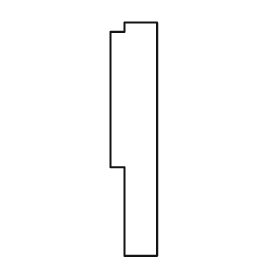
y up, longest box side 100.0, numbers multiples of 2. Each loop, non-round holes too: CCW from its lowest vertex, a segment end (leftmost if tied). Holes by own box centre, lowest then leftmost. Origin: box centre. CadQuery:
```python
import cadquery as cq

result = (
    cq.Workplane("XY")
    .moveTo(-4.0, -50.0)
    .lineTo(10.0, -50.0)
    .lineTo(10.0, 50.0)
    .lineTo(-4.0, 50.0)
    .lineTo(-4.0, 46.0)
    .lineTo(-10.0, 46.0)
    .lineTo(-10.0, -12.0)
    .lineTo(-4.0, -12.0)
    .close()
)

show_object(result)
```